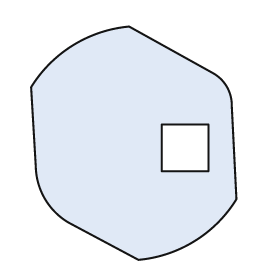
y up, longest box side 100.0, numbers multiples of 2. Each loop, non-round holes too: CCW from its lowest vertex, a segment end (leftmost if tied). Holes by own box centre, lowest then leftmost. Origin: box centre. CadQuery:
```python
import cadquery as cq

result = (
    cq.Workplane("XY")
    .moveTo(2.0, -50.0)
    .threePointArc((26.0, -42.0), (44.0, -24.0))
    .lineTo(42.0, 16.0)
    .threePointArc((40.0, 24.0), (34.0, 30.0))
    .lineTo(-2.0, 50.0)
    .threePointArc((-26.0, 42.0), (-44.0, 24.0))
    .lineTo(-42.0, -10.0)
    .threePointArc((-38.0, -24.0), (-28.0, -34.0))
    .close()
    .moveTo(12.0, -12.0)
    .lineTo(32.0, -12.0)
    .lineTo(32.0, 8.0)
    .lineTo(12.0, 8.0)
    .close()
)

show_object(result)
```